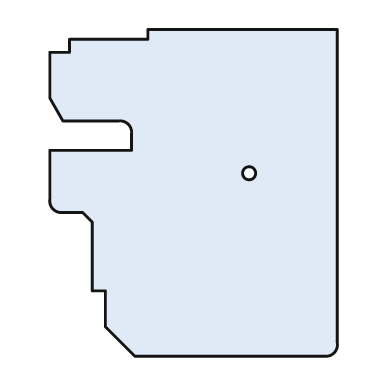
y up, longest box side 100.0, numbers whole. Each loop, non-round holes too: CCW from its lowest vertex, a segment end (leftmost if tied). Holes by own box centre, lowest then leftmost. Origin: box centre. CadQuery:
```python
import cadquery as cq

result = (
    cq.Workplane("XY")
    .moveTo(-18.0, -50.0)
    .lineTo(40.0, -50.0)
    .threePointArc((43.0, -49.0), (44.0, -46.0))
    .lineTo(44.0, 50.0)
    .lineTo(-14.0, 50.0)
    .lineTo(-14.0, 47.0)
    .lineTo(-38.0, 47.0)
    .lineTo(-38.0, 43.0)
    .lineTo(-44.0, 43.0)
    .lineTo(-44.0, 29.0)
    .lineTo(-40.0, 22.0)
    .lineTo(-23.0, 22.0)
    .threePointArc((-20.0, 21.0), (-19.0, 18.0))
    .lineTo(-19.0, 13.0)
    .lineTo(-44.0, 13.0)
    .lineTo(-44.0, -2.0)
    .threePointArc((-43.0, -5.0), (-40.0, -6.0))
    .lineTo(-34.0, -6.0)
    .lineTo(-31.0, -9.0)
    .lineTo(-31.0, -30.0)
    .lineTo(-27.0, -30.0)
    .lineTo(-27.0, -41.0)
    .close()
    .moveTo(17.0, 6.0)
    .circle(2.0)
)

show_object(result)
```